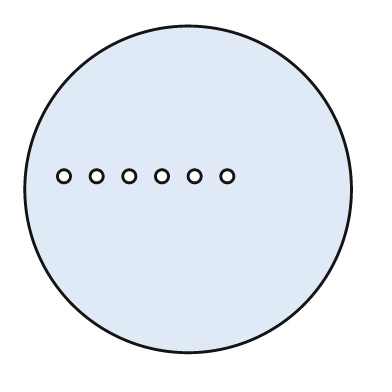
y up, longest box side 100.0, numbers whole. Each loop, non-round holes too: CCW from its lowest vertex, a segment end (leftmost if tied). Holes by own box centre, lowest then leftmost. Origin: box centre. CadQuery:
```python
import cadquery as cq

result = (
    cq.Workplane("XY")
    .moveTo(0.0, 0.0)
    .circle(50.0)
    .moveTo(-38.0, 4.0)
    .circle(2.0)
    .moveTo(-28.0, 4.0)
    .circle(2.0)
    .moveTo(-18.0, 4.0)
    .circle(2.0)
    .moveTo(-8.0, 4.0)
    .circle(2.0)
    .moveTo(2.0, 4.0)
    .circle(2.0)
    .moveTo(12.0, 4.0)
    .circle(2.0)
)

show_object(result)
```